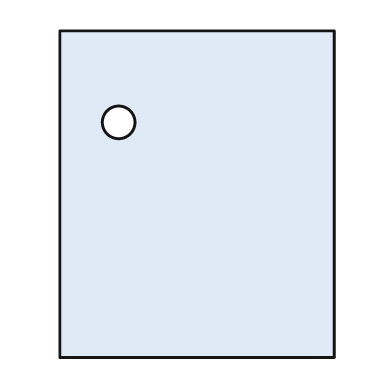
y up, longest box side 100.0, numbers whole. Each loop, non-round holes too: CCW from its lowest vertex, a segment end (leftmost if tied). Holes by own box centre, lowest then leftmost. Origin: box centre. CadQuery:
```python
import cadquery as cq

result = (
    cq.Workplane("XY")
    .moveTo(-42.0, -50.0)
    .lineTo(42.0, -50.0)
    .lineTo(42.0, 50.0)
    .lineTo(-42.0, 50.0)
    .close()
    .moveTo(-24.0, 22.0)
    .circle(5.0)
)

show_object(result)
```